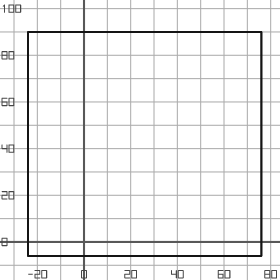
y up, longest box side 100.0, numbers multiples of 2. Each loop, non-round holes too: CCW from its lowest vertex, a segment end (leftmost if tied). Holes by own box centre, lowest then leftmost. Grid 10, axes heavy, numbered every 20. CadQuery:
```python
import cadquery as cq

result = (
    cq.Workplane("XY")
    .moveTo(-24.0, -6.0)
    .lineTo(76.0, -6.0)
    .lineTo(76.0, 90.0)
    .lineTo(-24.0, 90.0)
    .close()
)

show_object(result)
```